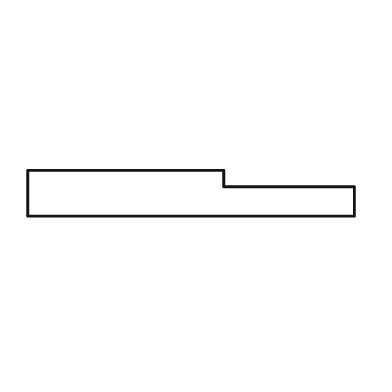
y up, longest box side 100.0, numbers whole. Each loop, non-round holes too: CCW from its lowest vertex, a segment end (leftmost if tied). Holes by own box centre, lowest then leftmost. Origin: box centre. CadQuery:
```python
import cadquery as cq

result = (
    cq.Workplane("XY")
    .moveTo(-50.0, -7.0)
    .lineTo(50.0, -7.0)
    .lineTo(50.0, 2.0)
    .lineTo(10.0, 2.0)
    .lineTo(10.0, 7.0)
    .lineTo(-50.0, 7.0)
    .close()
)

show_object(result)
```